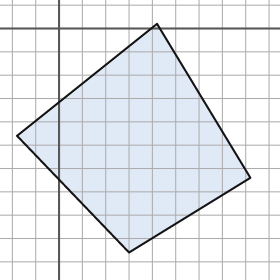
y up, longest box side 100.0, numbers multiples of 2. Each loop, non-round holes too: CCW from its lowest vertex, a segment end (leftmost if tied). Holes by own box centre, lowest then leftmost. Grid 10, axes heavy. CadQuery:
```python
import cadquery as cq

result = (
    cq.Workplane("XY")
    .moveTo(30.0, -96.0)
    .lineTo(82.0, -64.0)
    .lineTo(42.0, 2.0)
    .lineTo(-18.0, -46.0)
    .close()
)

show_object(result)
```